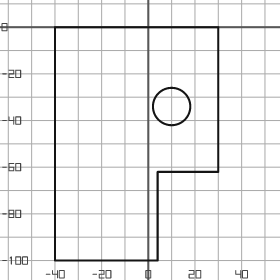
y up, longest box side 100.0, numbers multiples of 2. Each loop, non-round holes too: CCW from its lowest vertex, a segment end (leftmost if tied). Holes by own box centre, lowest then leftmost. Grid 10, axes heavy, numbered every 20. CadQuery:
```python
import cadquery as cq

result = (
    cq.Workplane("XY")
    .moveTo(-40.0, -100.0)
    .lineTo(4.0, -100.0)
    .lineTo(4.0, -62.0)
    .lineTo(30.0, -62.0)
    .lineTo(30.0, 0.0)
    .lineTo(-40.0, 0.0)
    .close()
    .moveTo(10.0, -34.0)
    .circle(8.0)
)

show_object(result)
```